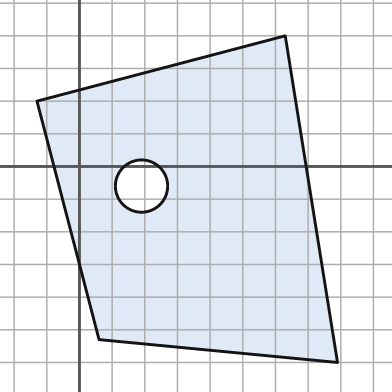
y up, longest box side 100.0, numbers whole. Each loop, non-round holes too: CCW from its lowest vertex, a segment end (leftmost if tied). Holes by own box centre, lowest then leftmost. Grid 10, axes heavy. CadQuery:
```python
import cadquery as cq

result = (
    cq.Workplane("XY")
    .moveTo(79.0, -60.0)
    .lineTo(63.0, 40.0)
    .lineTo(-13.0, 20.0)
    .lineTo(6.0, -53.0)
    .close()
    .moveTo(19.0, -6.0)
    .circle(8.0)
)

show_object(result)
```